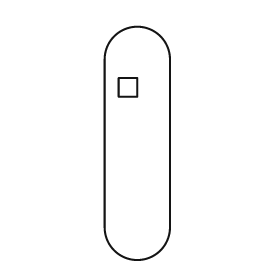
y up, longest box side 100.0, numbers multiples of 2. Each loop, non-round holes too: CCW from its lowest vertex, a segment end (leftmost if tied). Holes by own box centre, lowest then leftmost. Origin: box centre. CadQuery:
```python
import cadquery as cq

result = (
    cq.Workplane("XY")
    .moveTo(-14.0, -36.0)
    .threePointArc((0.0, -50.0), (14.0, -36.0))
    .lineTo(14.0, 36.0)
    .threePointArc((0.0, 50.0), (-14.0, 36.0))
    .close()
    .moveTo(-8.0, 20.0)
    .lineTo(0.0, 20.0)
    .lineTo(0.0, 28.0)
    .lineTo(-8.0, 28.0)
    .close()
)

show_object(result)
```